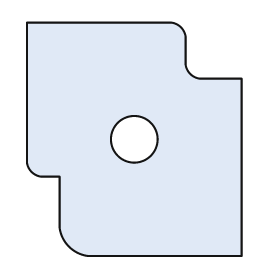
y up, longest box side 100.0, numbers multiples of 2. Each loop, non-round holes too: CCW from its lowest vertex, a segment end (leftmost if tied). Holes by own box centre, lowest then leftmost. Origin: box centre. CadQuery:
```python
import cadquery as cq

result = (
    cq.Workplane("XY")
    .moveTo(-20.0, -50.0)
    .lineTo(46.0, -50.0)
    .lineTo(46.0, 26.0)
    .lineTo(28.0, 26.0)
    .threePointArc((24.0, 28.0), (22.0, 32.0))
    .lineTo(22.0, 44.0)
    .threePointArc((20.0, 48.0), (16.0, 50.0))
    .lineTo(-46.0, 50.0)
    .lineTo(-46.0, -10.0)
    .threePointArc((-44.0, -14.0), (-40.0, -16.0))
    .lineTo(-32.0, -16.0)
    .lineTo(-32.0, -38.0)
    .threePointArc((-28.0, -46.0), (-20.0, -50.0))
    .close()
    .moveTo(0.0, 0.0)
    .circle(10.0)
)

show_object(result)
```